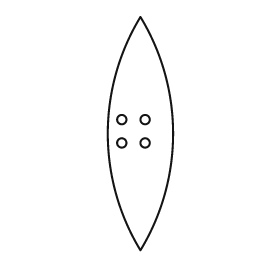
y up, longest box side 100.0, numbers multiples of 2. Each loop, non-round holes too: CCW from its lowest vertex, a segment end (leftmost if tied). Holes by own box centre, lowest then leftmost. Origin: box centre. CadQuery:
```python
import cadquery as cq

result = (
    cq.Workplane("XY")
    .moveTo(0.0, -50.0)
    .threePointArc((14.0, 0.0), (0.0, 50.0))
    .threePointArc((-14.0, 0.0), (0.0, -50.0))
    .close()
    .moveTo(-8.0, -4.0)
    .circle(2.0)
    .moveTo(2.0, -4.0)
    .circle(2.0)
    .moveTo(-8.0, 6.0)
    .circle(2.0)
    .moveTo(2.0, 6.0)
    .circle(2.0)
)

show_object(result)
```